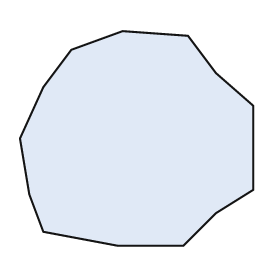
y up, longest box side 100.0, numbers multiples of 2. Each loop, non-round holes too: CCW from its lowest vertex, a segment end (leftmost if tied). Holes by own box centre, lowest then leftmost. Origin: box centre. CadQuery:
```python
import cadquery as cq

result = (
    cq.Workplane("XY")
    .moveTo(-8.0, -46.0)
    .lineTo(20.0, -46.0)
    .lineTo(34.0, -32.0)
    .lineTo(50.0, -22.0)
    .lineTo(50.0, 14.0)
    .lineTo(34.0, 28.0)
    .lineTo(22.0, 44.0)
    .lineTo(-6.0, 46.0)
    .lineTo(-28.0, 38.0)
    .lineTo(-40.0, 22.0)
    .lineTo(-50.0, 0.0)
    .lineTo(-46.0, -24.0)
    .lineTo(-40.0, -40.0)
    .close()
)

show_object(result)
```